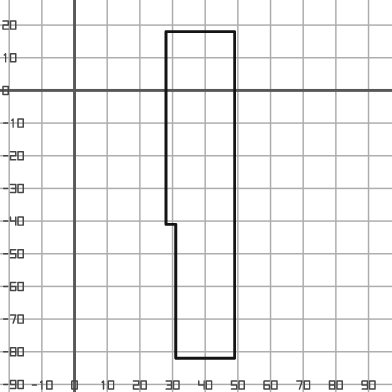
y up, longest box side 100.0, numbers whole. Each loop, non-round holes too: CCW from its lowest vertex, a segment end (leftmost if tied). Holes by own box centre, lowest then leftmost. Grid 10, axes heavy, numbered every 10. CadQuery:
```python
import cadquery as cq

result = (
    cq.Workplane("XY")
    .moveTo(31.0, -82.0)
    .lineTo(49.0, -82.0)
    .lineTo(49.0, 18.0)
    .lineTo(28.0, 18.0)
    .lineTo(28.0, -41.0)
    .lineTo(31.0, -41.0)
    .close()
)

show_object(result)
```